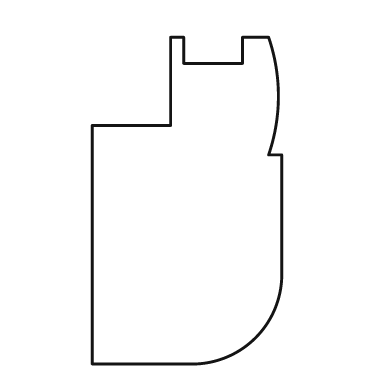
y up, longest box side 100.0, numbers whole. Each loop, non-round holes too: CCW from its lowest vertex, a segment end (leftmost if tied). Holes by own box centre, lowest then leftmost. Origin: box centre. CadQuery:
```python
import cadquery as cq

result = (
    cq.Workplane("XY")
    .moveTo(-29.0, -50.0)
    .lineTo(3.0, -50.0)
    .threePointArc((21.0, -42.0), (29.0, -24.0))
    .lineTo(29.0, 14.0)
    .lineTo(25.0, 14.0)
    .threePointArc((28.0, 32.0), (25.0, 50.0))
    .lineTo(17.0, 50.0)
    .lineTo(17.0, 42.0)
    .lineTo(-1.0, 42.0)
    .lineTo(-1.0, 50.0)
    .lineTo(-5.0, 50.0)
    .lineTo(-5.0, 23.0)
    .lineTo(-29.0, 23.0)
    .close()
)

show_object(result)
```